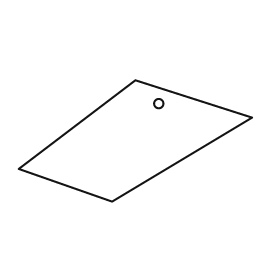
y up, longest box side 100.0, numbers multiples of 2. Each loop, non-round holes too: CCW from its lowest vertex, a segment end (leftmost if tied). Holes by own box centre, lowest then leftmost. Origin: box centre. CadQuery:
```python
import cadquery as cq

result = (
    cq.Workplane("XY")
    .moveTo(-10.0, -26.0)
    .lineTo(50.0, 10.0)
    .lineTo(0.0, 26.0)
    .lineTo(-50.0, -12.0)
    .close()
    .moveTo(10.0, 16.0)
    .circle(2.0)
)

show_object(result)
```